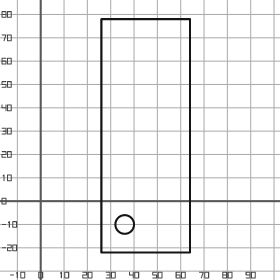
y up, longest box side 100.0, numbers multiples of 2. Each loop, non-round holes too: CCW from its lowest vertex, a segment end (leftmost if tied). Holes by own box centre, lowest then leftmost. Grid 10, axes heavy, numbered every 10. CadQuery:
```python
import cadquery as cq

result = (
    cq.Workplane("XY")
    .moveTo(26.0, -22.0)
    .lineTo(64.0, -22.0)
    .lineTo(64.0, 78.0)
    .lineTo(26.0, 78.0)
    .close()
    .moveTo(36.0, -10.0)
    .circle(4.0)
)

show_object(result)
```